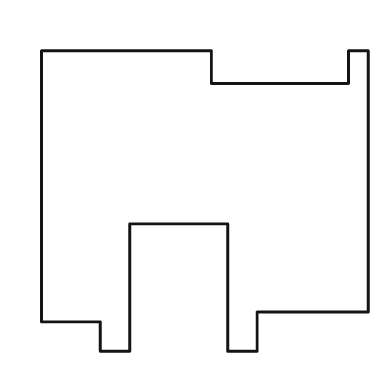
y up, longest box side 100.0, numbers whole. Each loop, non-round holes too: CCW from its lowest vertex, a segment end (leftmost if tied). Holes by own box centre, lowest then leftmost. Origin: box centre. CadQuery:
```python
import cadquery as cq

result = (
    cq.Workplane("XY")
    .moveTo(-32.0, -46.0)
    .lineTo(-23.0, -46.0)
    .lineTo(-23.0, -7.0)
    .lineTo(7.0, -7.0)
    .lineTo(7.0, -46.0)
    .lineTo(16.0, -46.0)
    .lineTo(16.0, -34.0)
    .lineTo(50.0, -34.0)
    .lineTo(50.0, 46.0)
    .lineTo(44.0, 46.0)
    .lineTo(44.0, 36.0)
    .lineTo(2.0, 36.0)
    .lineTo(2.0, 46.0)
    .lineTo(-50.0, 46.0)
    .lineTo(-50.0, -37.0)
    .lineTo(-32.0, -37.0)
    .close()
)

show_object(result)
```